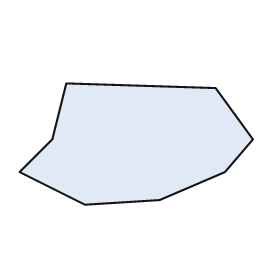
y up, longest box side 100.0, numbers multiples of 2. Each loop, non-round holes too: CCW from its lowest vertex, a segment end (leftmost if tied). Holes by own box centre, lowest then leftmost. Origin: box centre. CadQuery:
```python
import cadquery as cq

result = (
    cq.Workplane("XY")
    .moveTo(-22.0, -26.0)
    .lineTo(10.0, -24.0)
    .lineTo(38.0, -12.0)
    .lineTo(50.0, 2.0)
    .lineTo(34.0, 24.0)
    .lineTo(-30.0, 26.0)
    .lineTo(-36.0, 2.0)
    .lineTo(-50.0, -12.0)
    .close()
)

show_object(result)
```